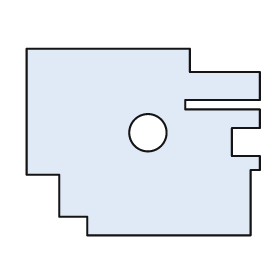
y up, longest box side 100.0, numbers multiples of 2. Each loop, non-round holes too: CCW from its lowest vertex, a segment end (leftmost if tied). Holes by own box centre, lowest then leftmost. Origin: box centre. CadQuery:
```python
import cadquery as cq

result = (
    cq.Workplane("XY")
    .moveTo(-24.0, -40.0)
    .lineTo(46.0, -40.0)
    .lineTo(46.0, -12.0)
    .lineTo(50.0, -12.0)
    .lineTo(50.0, -6.0)
    .lineTo(38.0, -6.0)
    .lineTo(38.0, 6.0)
    .lineTo(50.0, 6.0)
    .lineTo(50.0, 14.0)
    .lineTo(18.0, 14.0)
    .lineTo(18.0, 18.0)
    .lineTo(50.0, 18.0)
    .lineTo(50.0, 30.0)
    .lineTo(20.0, 30.0)
    .lineTo(20.0, 40.0)
    .lineTo(-50.0, 40.0)
    .lineTo(-50.0, -14.0)
    .lineTo(-36.0, -14.0)
    .lineTo(-36.0, -32.0)
    .lineTo(-24.0, -32.0)
    .close()
    .moveTo(2.0, 4.0)
    .circle(8.0)
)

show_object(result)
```